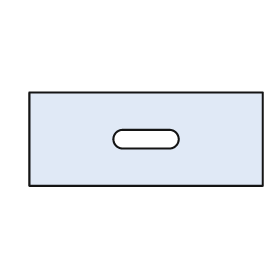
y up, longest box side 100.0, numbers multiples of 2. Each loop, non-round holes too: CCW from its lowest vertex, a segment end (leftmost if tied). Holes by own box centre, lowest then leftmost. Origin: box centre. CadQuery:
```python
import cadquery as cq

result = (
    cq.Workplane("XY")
    .moveTo(-50.0, -20.0)
    .lineTo(50.0, -20.0)
    .lineTo(50.0, 20.0)
    .lineTo(-50.0, 20.0)
    .close()
    .moveTo(-10.0, -4.0)
    .lineTo(10.0, -4.0)
    .threePointArc((14.0, 0.0), (10.0, 4.0))
    .lineTo(-10.0, 4.0)
    .threePointArc((-14.0, 0.0), (-10.0, -4.0))
    .close()
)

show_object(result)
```